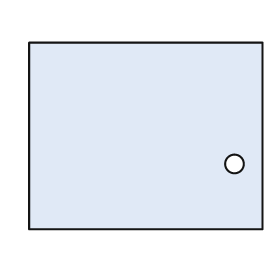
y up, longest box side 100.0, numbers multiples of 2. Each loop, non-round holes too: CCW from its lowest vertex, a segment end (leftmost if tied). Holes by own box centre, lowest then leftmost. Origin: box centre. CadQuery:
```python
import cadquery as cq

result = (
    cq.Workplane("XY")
    .moveTo(-50.0, -40.0)
    .lineTo(50.0, -40.0)
    .lineTo(50.0, 40.0)
    .lineTo(-50.0, 40.0)
    .close()
    .moveTo(38.0, -12.0)
    .circle(4.0)
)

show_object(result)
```